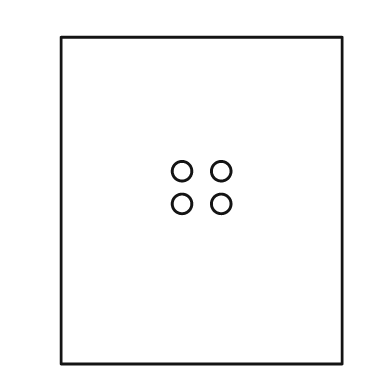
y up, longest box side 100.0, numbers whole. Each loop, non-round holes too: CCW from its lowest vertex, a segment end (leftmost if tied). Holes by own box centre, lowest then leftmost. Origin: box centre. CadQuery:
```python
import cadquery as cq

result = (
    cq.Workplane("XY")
    .moveTo(-43.0, -50.0)
    .lineTo(43.0, -50.0)
    .lineTo(43.0, 50.0)
    .lineTo(-43.0, 50.0)
    .close()
    .moveTo(-6.0, -1.0)
    .circle(3.0)
    .moveTo(6.0, -1.0)
    .circle(3.0)
    .moveTo(-6.0, 9.0)
    .circle(3.0)
    .moveTo(6.0, 9.0)
    .circle(3.0)
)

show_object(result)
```